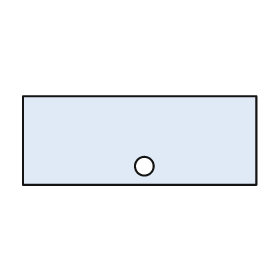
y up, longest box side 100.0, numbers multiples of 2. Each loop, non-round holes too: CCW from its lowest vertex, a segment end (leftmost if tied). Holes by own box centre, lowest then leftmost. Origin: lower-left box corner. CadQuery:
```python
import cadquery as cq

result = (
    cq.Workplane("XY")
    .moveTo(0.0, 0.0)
    .lineTo(100.0, 0.0)
    .lineTo(100.0, 38.0)
    .lineTo(0.0, 38.0)
    .close()
    .moveTo(52.0, 8.0)
    .circle(4.0)
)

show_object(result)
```